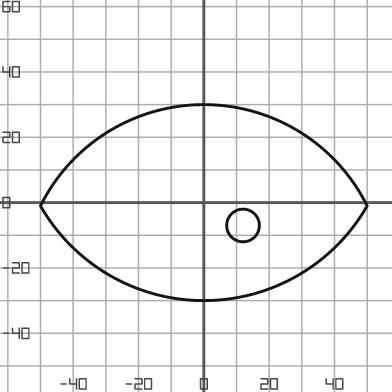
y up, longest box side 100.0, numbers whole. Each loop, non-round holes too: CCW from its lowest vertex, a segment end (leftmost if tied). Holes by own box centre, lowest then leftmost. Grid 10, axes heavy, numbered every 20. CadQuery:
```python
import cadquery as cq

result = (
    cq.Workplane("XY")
    .moveTo(-50.0, -1.0)
    .threePointArc((0.0, -30.0), (50.0, -1.0))
    .threePointArc((0.0, 30.0), (-50.0, -1.0))
    .close()
    .moveTo(12.0, -7.0)
    .circle(5.0)
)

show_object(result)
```